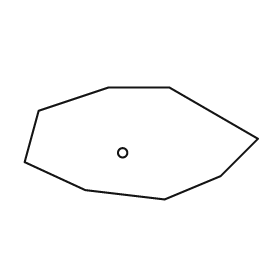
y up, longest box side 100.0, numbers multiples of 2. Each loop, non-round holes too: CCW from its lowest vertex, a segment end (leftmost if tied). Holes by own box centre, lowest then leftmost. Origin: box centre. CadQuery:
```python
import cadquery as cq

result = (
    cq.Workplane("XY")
    .moveTo(10.0, -24.0)
    .lineTo(34.0, -14.0)
    .lineTo(50.0, 2.0)
    .lineTo(12.0, 24.0)
    .lineTo(-14.0, 24.0)
    .lineTo(-44.0, 14.0)
    .lineTo(-50.0, -8.0)
    .lineTo(-24.0, -20.0)
    .close()
    .moveTo(-8.0, -4.0)
    .circle(2.0)
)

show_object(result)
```